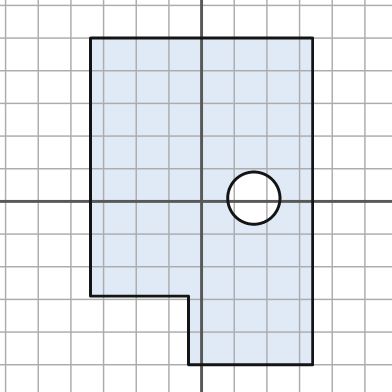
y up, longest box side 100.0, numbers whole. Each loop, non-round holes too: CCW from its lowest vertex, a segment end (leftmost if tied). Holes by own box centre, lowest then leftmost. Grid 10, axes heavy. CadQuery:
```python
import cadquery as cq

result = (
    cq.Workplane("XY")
    .moveTo(-4.0, -50.0)
    .lineTo(34.0, -50.0)
    .lineTo(34.0, 50.0)
    .lineTo(-34.0, 50.0)
    .lineTo(-34.0, -29.0)
    .lineTo(-4.0, -29.0)
    .close()
    .moveTo(16.0, 1.0)
    .circle(8.0)
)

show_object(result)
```